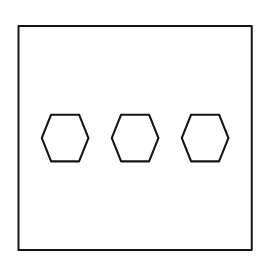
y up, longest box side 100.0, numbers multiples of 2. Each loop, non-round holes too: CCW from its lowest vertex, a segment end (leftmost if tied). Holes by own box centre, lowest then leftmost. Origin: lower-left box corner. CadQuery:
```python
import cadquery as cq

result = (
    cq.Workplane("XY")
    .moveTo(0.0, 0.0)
    .lineTo(100.0, 0.0)
    .lineTo(100.0, 96.0)
    .lineTo(0.0, 96.0)
    .close()
    .moveTo(14.0, 38.0)
    .lineTo(26.0, 38.0)
    .lineTo(30.0, 48.0)
    .lineTo(26.0, 58.0)
    .lineTo(14.0, 58.0)
    .lineTo(10.0, 48.0)
    .close()
    .moveTo(44.0, 38.0)
    .lineTo(56.0, 38.0)
    .lineTo(60.0, 48.0)
    .lineTo(56.0, 58.0)
    .lineTo(44.0, 58.0)
    .lineTo(40.0, 48.0)
    .close()
    .moveTo(74.0, 38.0)
    .lineTo(86.0, 38.0)
    .lineTo(90.0, 48.0)
    .lineTo(86.0, 58.0)
    .lineTo(74.0, 58.0)
    .lineTo(70.0, 48.0)
    .close()
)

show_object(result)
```